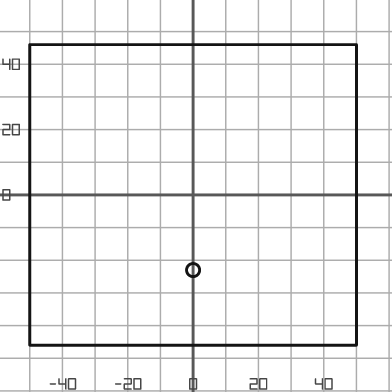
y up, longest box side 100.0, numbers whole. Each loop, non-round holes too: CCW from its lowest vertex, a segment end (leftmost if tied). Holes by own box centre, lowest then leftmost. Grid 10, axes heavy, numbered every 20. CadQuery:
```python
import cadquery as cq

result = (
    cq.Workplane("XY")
    .moveTo(-50.0, -46.0)
    .lineTo(50.0, -46.0)
    .lineTo(50.0, 46.0)
    .lineTo(-50.0, 46.0)
    .close()
    .moveTo(0.0, -23.0)
    .circle(2.0)
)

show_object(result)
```